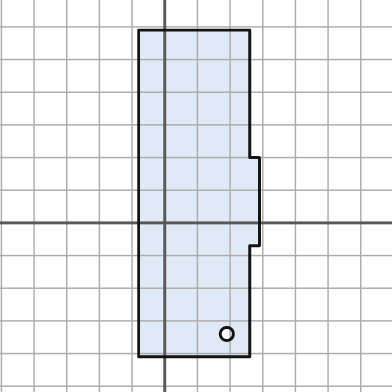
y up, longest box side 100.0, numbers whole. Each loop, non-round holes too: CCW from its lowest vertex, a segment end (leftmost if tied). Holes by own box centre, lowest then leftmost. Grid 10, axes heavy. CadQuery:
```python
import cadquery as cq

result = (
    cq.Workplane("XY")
    .moveTo(-8.0, -41.0)
    .lineTo(26.0, -41.0)
    .lineTo(26.0, -7.0)
    .lineTo(29.0, -7.0)
    .lineTo(29.0, 20.0)
    .lineTo(26.0, 20.0)
    .lineTo(26.0, 59.0)
    .lineTo(-8.0, 59.0)
    .close()
    .moveTo(19.0, -34.0)
    .circle(2.0)
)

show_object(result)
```